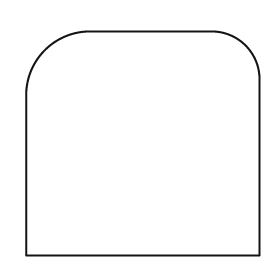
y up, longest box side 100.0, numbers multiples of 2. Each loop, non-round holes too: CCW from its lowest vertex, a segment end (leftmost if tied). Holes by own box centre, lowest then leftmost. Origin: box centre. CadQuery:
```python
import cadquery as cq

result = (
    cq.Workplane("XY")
    .moveTo(-50.0, -48.0)
    .lineTo(50.0, -48.0)
    .lineTo(50.0, 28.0)
    .threePointArc((44.0, 42.0), (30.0, 48.0))
    .lineTo(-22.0, 48.0)
    .threePointArc((-42.0, 40.0), (-50.0, 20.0))
    .close()
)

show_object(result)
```